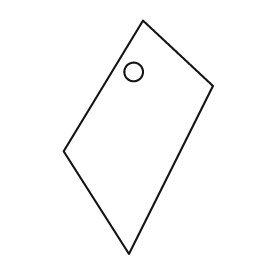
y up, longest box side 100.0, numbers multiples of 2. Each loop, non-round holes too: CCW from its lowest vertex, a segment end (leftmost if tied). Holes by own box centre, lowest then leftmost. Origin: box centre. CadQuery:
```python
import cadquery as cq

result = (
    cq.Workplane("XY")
    .moveTo(-4.0, -50.0)
    .lineTo(32.0, 22.0)
    .lineTo(2.0, 50.0)
    .lineTo(-32.0, -6.0)
    .close()
    .moveTo(-2.0, 28.0)
    .circle(4.0)
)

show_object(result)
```